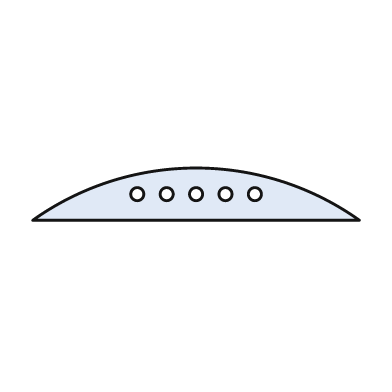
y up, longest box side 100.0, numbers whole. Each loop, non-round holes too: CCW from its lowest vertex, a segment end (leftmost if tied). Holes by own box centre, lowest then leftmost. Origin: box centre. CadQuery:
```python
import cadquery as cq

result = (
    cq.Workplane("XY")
    .moveTo(-50.0, -8.0)
    .lineTo(50.0, -8.0)
    .threePointArc((0.0, 8.0), (-50.0, -8.0))
    .close()
    .moveTo(-18.0, 0.0)
    .circle(2.0)
    .moveTo(-9.0, 0.0)
    .circle(2.0)
    .moveTo(0.0, 0.0)
    .circle(2.0)
    .moveTo(9.0, 0.0)
    .circle(2.0)
    .moveTo(18.0, 0.0)
    .circle(2.0)
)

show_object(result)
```